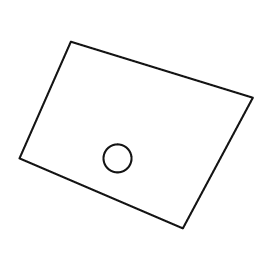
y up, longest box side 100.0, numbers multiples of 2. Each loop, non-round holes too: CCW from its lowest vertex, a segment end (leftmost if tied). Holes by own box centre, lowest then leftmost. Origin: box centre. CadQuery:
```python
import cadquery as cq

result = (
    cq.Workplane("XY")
    .moveTo(20.0, -40.0)
    .lineTo(50.0, 16.0)
    .lineTo(-28.0, 40.0)
    .lineTo(-50.0, -10.0)
    .close()
    .moveTo(-8.0, -10.0)
    .circle(6.0)
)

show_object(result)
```